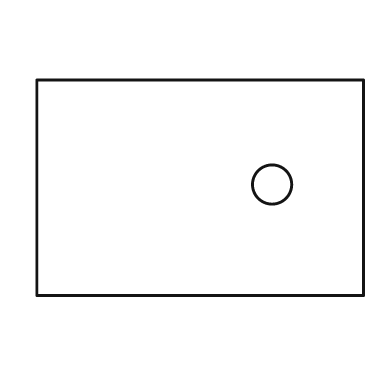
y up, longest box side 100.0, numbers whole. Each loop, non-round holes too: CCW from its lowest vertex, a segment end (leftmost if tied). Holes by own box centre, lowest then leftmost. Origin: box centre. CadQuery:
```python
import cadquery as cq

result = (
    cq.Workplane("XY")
    .moveTo(-50.0, -33.0)
    .lineTo(50.0, -33.0)
    .lineTo(50.0, 33.0)
    .lineTo(-50.0, 33.0)
    .close()
    .moveTo(22.0, 1.0)
    .circle(6.0)
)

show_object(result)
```